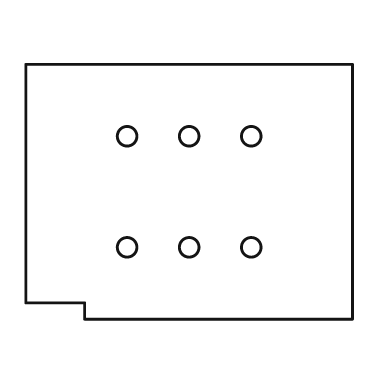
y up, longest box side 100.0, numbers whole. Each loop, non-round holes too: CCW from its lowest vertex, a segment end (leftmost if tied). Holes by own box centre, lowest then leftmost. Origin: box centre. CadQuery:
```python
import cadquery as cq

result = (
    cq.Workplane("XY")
    .moveTo(-32.0, -39.0)
    .lineTo(50.0, -39.0)
    .lineTo(50.0, 39.0)
    .lineTo(-50.0, 39.0)
    .lineTo(-50.0, -34.0)
    .lineTo(-32.0, -34.0)
    .close()
    .moveTo(-19.0, -17.0)
    .circle(3.0)
    .moveTo(0.0, -17.0)
    .circle(3.0)
    .moveTo(19.0, -17.0)
    .circle(3.0)
    .moveTo(-19.0, 17.0)
    .circle(3.0)
    .moveTo(0.0, 17.0)
    .circle(3.0)
    .moveTo(19.0, 17.0)
    .circle(3.0)
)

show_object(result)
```